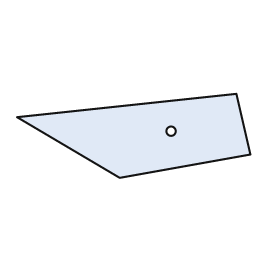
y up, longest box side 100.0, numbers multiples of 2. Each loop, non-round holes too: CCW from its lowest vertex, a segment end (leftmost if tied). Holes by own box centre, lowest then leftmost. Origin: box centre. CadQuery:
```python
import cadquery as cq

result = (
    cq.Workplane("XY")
    .moveTo(-6.0, -18.0)
    .lineTo(50.0, -8.0)
    .lineTo(44.0, 18.0)
    .lineTo(-50.0, 8.0)
    .close()
    .moveTo(16.0, 2.0)
    .circle(2.0)
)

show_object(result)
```